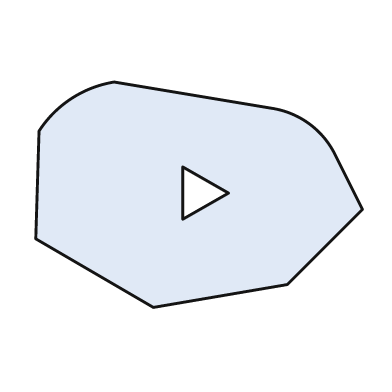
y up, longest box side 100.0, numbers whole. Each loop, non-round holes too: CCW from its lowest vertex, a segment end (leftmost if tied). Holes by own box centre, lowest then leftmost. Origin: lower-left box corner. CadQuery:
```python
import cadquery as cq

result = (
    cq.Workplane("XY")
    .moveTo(36.0, 0.0)
    .lineTo(77.0, 7.0)
    .lineTo(100.0, 30.0)
    .lineTo(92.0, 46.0)
    .threePointArc((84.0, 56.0), (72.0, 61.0))
    .lineTo(24.0, 69.0)
    .threePointArc((11.0, 64.0), (1.0, 54.0))
    .lineTo(0.0, 21.0)
    .close()
    .moveTo(45.0, 27.0)
    .lineTo(59.0, 35.0)
    .lineTo(45.0, 43.0)
    .close()
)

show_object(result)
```